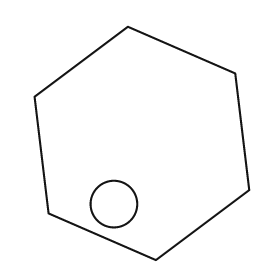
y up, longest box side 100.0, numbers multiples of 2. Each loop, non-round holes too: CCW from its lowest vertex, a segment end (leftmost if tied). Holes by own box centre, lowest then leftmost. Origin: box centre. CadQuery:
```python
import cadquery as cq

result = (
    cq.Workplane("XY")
    .moveTo(6.0, -50.0)
    .lineTo(46.0, -20.0)
    .lineTo(40.0, 30.0)
    .lineTo(-6.0, 50.0)
    .lineTo(-46.0, 20.0)
    .lineTo(-40.0, -30.0)
    .close()
    .moveTo(-12.0, -26.0)
    .circle(10.0)
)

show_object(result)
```